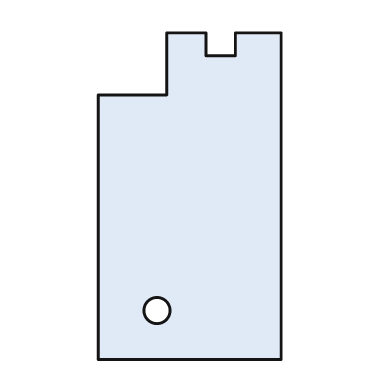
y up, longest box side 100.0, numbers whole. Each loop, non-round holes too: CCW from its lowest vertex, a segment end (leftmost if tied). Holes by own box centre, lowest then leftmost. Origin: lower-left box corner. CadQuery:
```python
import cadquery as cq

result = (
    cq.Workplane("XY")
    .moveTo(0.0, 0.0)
    .lineTo(56.0, 0.0)
    .lineTo(56.0, 100.0)
    .lineTo(42.0, 100.0)
    .lineTo(42.0, 93.0)
    .lineTo(33.0, 93.0)
    .lineTo(33.0, 100.0)
    .lineTo(21.0, 100.0)
    .lineTo(21.0, 81.0)
    .lineTo(0.0, 81.0)
    .close()
    .moveTo(18.0, 15.0)
    .circle(4.0)
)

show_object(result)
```